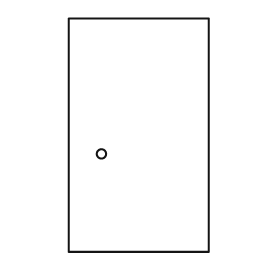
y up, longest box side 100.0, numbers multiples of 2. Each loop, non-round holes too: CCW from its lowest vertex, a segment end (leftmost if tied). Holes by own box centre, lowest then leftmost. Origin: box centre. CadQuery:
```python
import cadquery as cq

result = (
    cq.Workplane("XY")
    .moveTo(-30.0, -50.0)
    .lineTo(30.0, -50.0)
    .lineTo(30.0, 50.0)
    .lineTo(-30.0, 50.0)
    .close()
    .moveTo(-16.0, -8.0)
    .circle(2.0)
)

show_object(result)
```